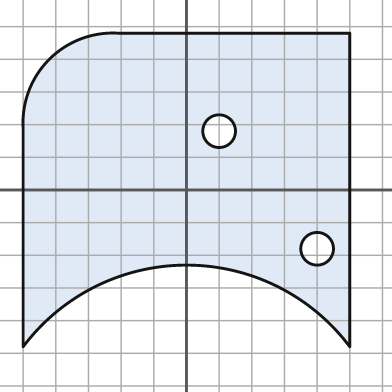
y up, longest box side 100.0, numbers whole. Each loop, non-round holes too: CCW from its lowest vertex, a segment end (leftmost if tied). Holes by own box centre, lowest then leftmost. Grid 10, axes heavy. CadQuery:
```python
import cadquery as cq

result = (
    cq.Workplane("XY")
    .moveTo(-50.0, -48.0)
    .threePointArc((0.0, -23.0), (50.0, -48.0))
    .lineTo(50.0, 48.0)
    .lineTo(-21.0, 48.0)
    .threePointArc((-42.0, 40.0), (-50.0, 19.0))
    .close()
    .moveTo(40.0, -18.0)
    .circle(5.0)
    .moveTo(10.0, 18.0)
    .circle(5.0)
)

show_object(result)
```